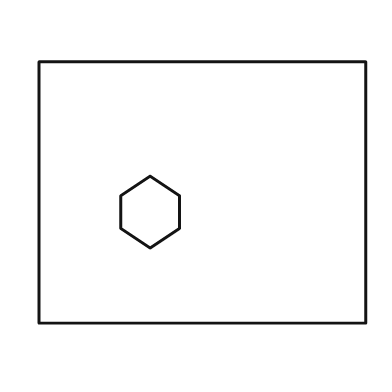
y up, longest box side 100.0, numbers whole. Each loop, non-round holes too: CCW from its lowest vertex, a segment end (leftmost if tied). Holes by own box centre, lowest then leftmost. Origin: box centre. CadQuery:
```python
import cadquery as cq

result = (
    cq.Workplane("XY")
    .moveTo(-50.0, -40.0)
    .lineTo(50.0, -40.0)
    .lineTo(50.0, 40.0)
    .lineTo(-50.0, 40.0)
    .close()
    .moveTo(-16.0, -17.0)
    .lineTo(-7.0, -11.0)
    .lineTo(-7.0, -1.0)
    .lineTo(-16.0, 5.0)
    .lineTo(-25.0, -1.0)
    .lineTo(-25.0, -11.0)
    .close()
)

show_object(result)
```